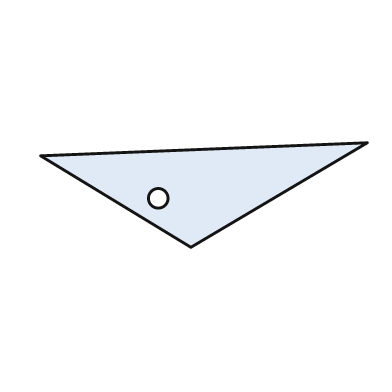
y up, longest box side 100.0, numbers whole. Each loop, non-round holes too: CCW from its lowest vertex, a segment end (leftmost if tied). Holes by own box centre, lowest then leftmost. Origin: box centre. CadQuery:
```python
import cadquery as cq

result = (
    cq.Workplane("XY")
    .moveTo(-4.0, -16.0)
    .lineTo(50.0, 16.0)
    .lineTo(-50.0, 12.0)
    .close()
    .moveTo(-14.0, -1.0)
    .circle(3.0)
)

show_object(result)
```